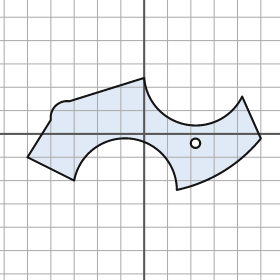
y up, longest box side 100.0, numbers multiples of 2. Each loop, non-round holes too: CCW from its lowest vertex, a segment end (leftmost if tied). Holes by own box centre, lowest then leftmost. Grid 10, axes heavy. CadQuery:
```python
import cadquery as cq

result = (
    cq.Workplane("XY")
    .moveTo(14.0, -24.0)
    .threePointArc((34.0, -16.0), (50.0, -2.0))
    .lineTo(42.0, 16.0)
    .threePointArc((18.0, 4.0), (0.0, 24.0))
    .lineTo(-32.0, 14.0)
    .threePointArc((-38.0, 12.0), (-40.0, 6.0))
    .lineTo(-50.0, -10.0)
    .lineTo(-30.0, -20.0)
    .threePointArc((-6.0, -2.0), (14.0, -24.0))
    .close()
    .moveTo(22.0, -4.0)
    .circle(2.0)
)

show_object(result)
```